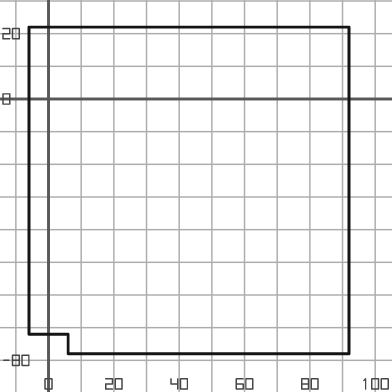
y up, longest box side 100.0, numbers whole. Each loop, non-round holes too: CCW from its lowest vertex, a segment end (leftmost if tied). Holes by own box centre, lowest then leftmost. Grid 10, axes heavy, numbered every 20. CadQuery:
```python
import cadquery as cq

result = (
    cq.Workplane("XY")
    .moveTo(6.0, -78.0)
    .lineTo(92.0, -78.0)
    .lineTo(92.0, 22.0)
    .lineTo(-6.0, 22.0)
    .lineTo(-6.0, -72.0)
    .lineTo(6.0, -72.0)
    .close()
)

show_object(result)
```